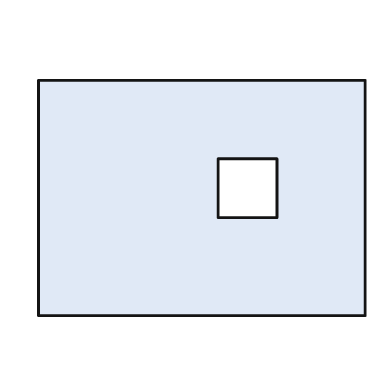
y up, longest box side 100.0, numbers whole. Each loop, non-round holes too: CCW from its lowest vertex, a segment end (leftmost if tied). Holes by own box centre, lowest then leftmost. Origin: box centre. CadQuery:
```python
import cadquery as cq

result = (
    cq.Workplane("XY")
    .moveTo(-50.0, -36.0)
    .lineTo(50.0, -36.0)
    .lineTo(50.0, 36.0)
    .lineTo(-50.0, 36.0)
    .close()
    .moveTo(5.0, -6.0)
    .lineTo(23.0, -6.0)
    .lineTo(23.0, 12.0)
    .lineTo(5.0, 12.0)
    .close()
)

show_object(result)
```